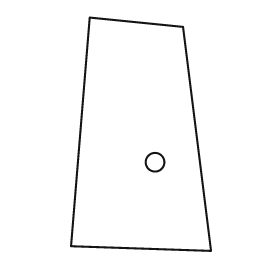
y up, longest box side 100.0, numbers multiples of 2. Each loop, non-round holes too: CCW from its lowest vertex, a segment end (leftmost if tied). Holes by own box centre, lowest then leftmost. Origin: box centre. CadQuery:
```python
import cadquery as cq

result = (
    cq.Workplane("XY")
    .moveTo(30.0, -50.0)
    .lineTo(18.0, 46.0)
    .lineTo(-22.0, 50.0)
    .lineTo(-30.0, -48.0)
    .close()
    .moveTo(6.0, -12.0)
    .circle(4.0)
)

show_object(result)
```